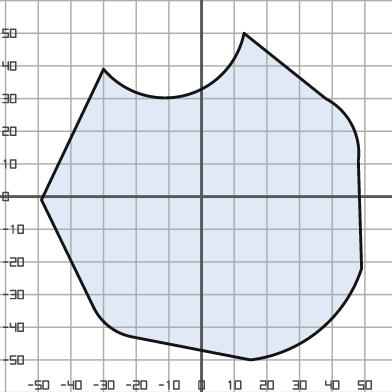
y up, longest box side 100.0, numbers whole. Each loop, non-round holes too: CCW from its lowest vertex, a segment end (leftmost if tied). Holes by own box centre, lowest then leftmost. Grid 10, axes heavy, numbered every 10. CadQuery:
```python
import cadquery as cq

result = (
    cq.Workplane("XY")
    .moveTo(15.0, -50.0)
    .threePointArc((36.0, -41.0), (49.0, -22.0))
    .lineTo(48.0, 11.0)
    .threePointArc((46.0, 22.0), (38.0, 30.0))
    .lineTo(13.0, 50.0)
    .threePointArc((-5.0, 31.0), (-30.0, 39.0))
    .lineTo(-49.0, -1.0)
    .lineTo(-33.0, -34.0)
    .threePointArc((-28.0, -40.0), (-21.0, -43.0))
    .close()
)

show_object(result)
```